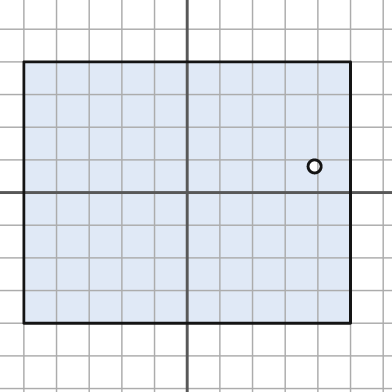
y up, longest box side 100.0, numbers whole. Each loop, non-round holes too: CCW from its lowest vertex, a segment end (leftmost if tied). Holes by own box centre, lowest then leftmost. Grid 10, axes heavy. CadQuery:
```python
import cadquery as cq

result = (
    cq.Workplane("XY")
    .moveTo(-50.0, -40.0)
    .lineTo(50.0, -40.0)
    .lineTo(50.0, 40.0)
    .lineTo(-50.0, 40.0)
    .close()
    .moveTo(39.0, 8.0)
    .circle(2.0)
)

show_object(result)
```